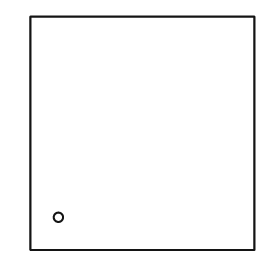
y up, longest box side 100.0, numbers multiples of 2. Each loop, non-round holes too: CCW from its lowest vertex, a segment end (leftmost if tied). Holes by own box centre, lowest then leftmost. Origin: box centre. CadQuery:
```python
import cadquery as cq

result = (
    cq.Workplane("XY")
    .moveTo(-48.0, -50.0)
    .lineTo(48.0, -50.0)
    .lineTo(48.0, 50.0)
    .lineTo(-48.0, 50.0)
    .close()
    .moveTo(-36.0, -36.0)
    .circle(2.0)
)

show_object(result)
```